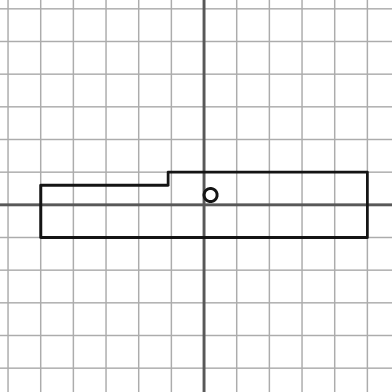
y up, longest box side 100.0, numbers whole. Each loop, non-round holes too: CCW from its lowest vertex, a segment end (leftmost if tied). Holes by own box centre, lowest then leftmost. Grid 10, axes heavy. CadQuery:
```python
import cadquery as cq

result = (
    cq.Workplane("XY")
    .moveTo(-50.0, -10.0)
    .lineTo(50.0, -10.0)
    .lineTo(50.0, 10.0)
    .lineTo(-11.0, 10.0)
    .lineTo(-11.0, 6.0)
    .lineTo(-50.0, 6.0)
    .close()
    .moveTo(2.0, 3.0)
    .circle(2.0)
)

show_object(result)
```